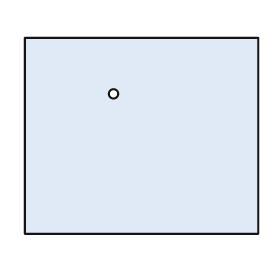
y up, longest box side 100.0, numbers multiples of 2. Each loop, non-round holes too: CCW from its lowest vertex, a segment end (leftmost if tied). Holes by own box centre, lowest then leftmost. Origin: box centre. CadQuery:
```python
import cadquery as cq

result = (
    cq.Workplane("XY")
    .moveTo(-50.0, -42.0)
    .lineTo(50.0, -42.0)
    .lineTo(50.0, 42.0)
    .lineTo(-50.0, 42.0)
    .close()
    .moveTo(-12.0, 18.0)
    .circle(2.0)
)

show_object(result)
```